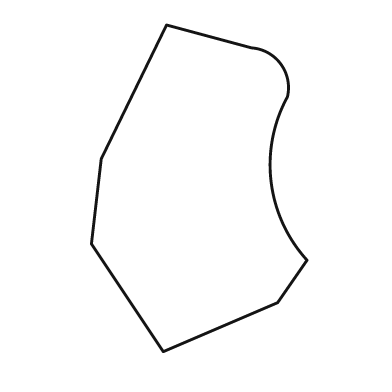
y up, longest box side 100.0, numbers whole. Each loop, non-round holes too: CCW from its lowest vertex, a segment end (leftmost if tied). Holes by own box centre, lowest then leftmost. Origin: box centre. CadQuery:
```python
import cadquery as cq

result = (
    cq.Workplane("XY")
    .moveTo(-11.0, -50.0)
    .lineTo(24.0, -35.0)
    .lineTo(33.0, -22.0)
    .threePointArc((22.0, 2.0), (27.0, 28.0))
    .threePointArc((25.0, 38.0), (16.0, 43.0))
    .lineTo(-10.0, 50.0)
    .lineTo(-30.0, 9.0)
    .lineTo(-33.0, -17.0)
    .close()
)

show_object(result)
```